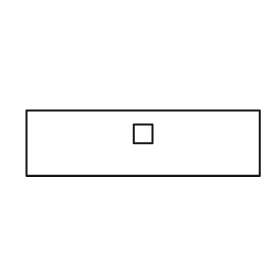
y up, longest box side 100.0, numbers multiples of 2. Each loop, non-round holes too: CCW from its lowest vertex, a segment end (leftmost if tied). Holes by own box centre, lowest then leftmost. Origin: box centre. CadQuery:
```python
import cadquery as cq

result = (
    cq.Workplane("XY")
    .moveTo(-50.0, -14.0)
    .lineTo(50.0, -14.0)
    .lineTo(50.0, 14.0)
    .lineTo(-50.0, 14.0)
    .close()
    .moveTo(-4.0, 0.0)
    .lineTo(4.0, 0.0)
    .lineTo(4.0, 8.0)
    .lineTo(-4.0, 8.0)
    .close()
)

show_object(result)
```